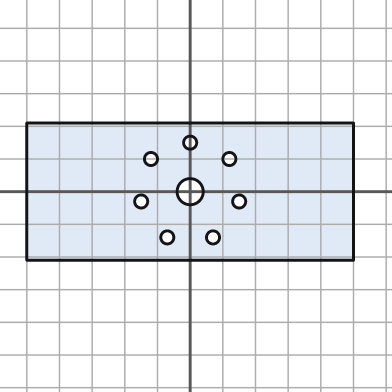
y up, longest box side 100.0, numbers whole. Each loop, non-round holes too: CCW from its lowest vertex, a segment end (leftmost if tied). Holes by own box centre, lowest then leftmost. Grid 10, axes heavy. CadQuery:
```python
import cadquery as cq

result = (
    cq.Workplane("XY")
    .moveTo(-50.0, -21.0)
    .lineTo(50.0, -21.0)
    .lineTo(50.0, 21.0)
    .lineTo(-50.0, 21.0)
    .close()
    .moveTo(-7.0, -14.0)
    .circle(2.0)
    .moveTo(7.0, -14.0)
    .circle(2.0)
    .moveTo(-15.0, -3.0)
    .circle(2.0)
    .moveTo(15.0, -3.0)
    .circle(2.0)
    .moveTo(0.0, 0.0)
    .circle(4.0)
    .moveTo(-12.0, 10.0)
    .circle(2.0)
    .moveTo(12.0, 10.0)
    .circle(2.0)
    .moveTo(0.0, 15.0)
    .circle(2.0)
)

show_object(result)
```